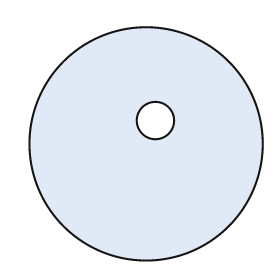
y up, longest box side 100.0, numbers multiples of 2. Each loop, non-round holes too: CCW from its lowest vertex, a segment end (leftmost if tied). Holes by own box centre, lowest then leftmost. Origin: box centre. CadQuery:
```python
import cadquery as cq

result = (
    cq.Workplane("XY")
    .moveTo(0.0, 0.0)
    .circle(50.0)
    .moveTo(4.0, 10.0)
    .circle(8.0)
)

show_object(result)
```